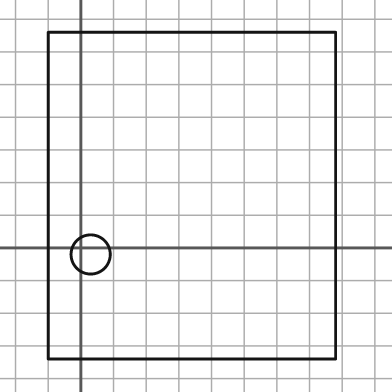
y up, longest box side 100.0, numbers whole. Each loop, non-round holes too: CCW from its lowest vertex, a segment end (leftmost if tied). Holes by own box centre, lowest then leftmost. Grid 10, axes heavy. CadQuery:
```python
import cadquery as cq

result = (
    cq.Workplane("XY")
    .moveTo(-10.0, -34.0)
    .lineTo(78.0, -34.0)
    .lineTo(78.0, 66.0)
    .lineTo(-10.0, 66.0)
    .close()
    .moveTo(3.0, -2.0)
    .circle(6.0)
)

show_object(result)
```